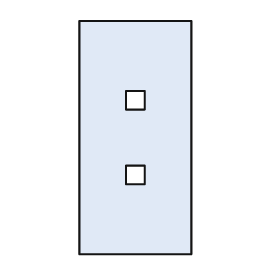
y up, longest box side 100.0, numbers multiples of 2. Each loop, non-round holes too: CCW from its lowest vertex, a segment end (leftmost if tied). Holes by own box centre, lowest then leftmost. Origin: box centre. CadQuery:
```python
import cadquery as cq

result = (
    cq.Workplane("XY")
    .moveTo(-24.0, -50.0)
    .lineTo(24.0, -50.0)
    .lineTo(24.0, 50.0)
    .lineTo(-24.0, 50.0)
    .close()
    .moveTo(-4.0, -20.0)
    .lineTo(4.0, -20.0)
    .lineTo(4.0, -12.0)
    .lineTo(-4.0, -12.0)
    .close()
    .moveTo(-4.0, 12.0)
    .lineTo(4.0, 12.0)
    .lineTo(4.0, 20.0)
    .lineTo(-4.0, 20.0)
    .close()
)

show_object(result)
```